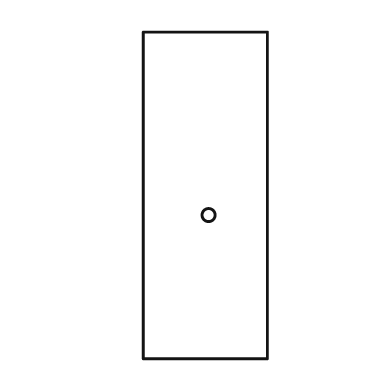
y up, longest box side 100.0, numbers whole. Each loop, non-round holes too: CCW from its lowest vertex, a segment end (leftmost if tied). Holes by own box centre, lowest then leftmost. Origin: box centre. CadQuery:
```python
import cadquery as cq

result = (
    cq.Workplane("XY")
    .moveTo(-19.0, -50.0)
    .lineTo(19.0, -50.0)
    .lineTo(19.0, 50.0)
    .lineTo(-19.0, 50.0)
    .close()
    .moveTo(1.0, -6.0)
    .circle(2.0)
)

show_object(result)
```